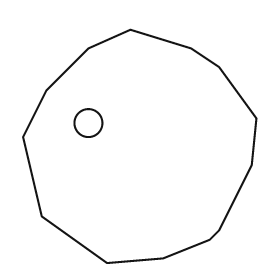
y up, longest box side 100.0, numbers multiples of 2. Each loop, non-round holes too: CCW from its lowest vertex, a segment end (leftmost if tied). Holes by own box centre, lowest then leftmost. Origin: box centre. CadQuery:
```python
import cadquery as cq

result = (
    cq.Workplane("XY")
    .moveTo(-14.0, -50.0)
    .lineTo(10.0, -48.0)
    .lineTo(30.0, -40.0)
    .lineTo(34.0, -36.0)
    .lineTo(48.0, -8.0)
    .lineTo(50.0, 12.0)
    .lineTo(34.0, 34.0)
    .lineTo(22.0, 42.0)
    .lineTo(-4.0, 50.0)
    .lineTo(-22.0, 42.0)
    .lineTo(-40.0, 24.0)
    .lineTo(-50.0, 4.0)
    .lineTo(-42.0, -30.0)
    .close()
    .moveTo(-22.0, 10.0)
    .circle(6.0)
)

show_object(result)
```